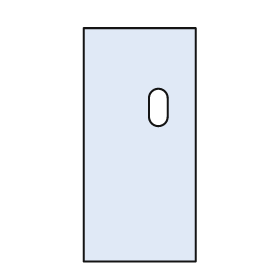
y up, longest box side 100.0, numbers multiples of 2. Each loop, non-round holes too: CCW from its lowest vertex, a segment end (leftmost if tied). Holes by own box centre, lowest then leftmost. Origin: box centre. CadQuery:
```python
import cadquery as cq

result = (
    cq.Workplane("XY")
    .moveTo(-24.0, -50.0)
    .lineTo(24.0, -50.0)
    .lineTo(24.0, 50.0)
    .lineTo(-24.0, 50.0)
    .close()
    .moveTo(4.0, 12.0)
    .threePointArc((8.0, 8.0), (12.0, 12.0))
    .lineTo(12.0, 20.0)
    .threePointArc((8.0, 24.0), (4.0, 20.0))
    .close()
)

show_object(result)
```